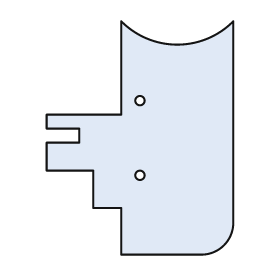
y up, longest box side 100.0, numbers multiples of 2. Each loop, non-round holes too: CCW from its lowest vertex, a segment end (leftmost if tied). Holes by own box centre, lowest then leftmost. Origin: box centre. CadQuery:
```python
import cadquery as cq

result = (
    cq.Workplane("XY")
    .moveTo(-8.0, -50.0)
    .lineTo(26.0, -50.0)
    .threePointArc((36.0, -46.0), (40.0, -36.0))
    .lineTo(40.0, 50.0)
    .threePointArc((16.0, 40.0), (-8.0, 50.0))
    .lineTo(-8.0, 10.0)
    .lineTo(-40.0, 10.0)
    .lineTo(-40.0, 4.0)
    .lineTo(-26.0, 4.0)
    .lineTo(-26.0, -2.0)
    .lineTo(-40.0, -2.0)
    .lineTo(-40.0, -14.0)
    .lineTo(-20.0, -14.0)
    .lineTo(-20.0, -30.0)
    .lineTo(-8.0, -30.0)
    .close()
    .moveTo(0.0, -16.0)
    .circle(2.0)
    .moveTo(0.0, 16.0)
    .circle(2.0)
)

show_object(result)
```